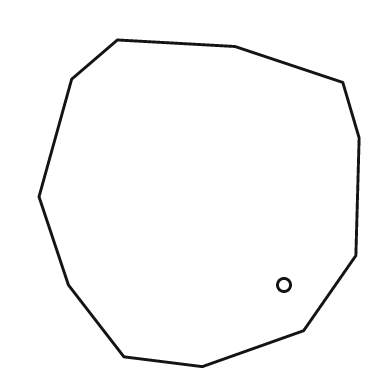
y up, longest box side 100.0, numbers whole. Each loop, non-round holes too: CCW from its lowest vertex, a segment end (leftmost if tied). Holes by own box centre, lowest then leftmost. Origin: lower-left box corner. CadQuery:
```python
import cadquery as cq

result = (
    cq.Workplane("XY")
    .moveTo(50.0, 0.0)
    .lineTo(81.0, 11.0)
    .lineTo(97.0, 34.0)
    .lineTo(98.0, 70.0)
    .lineTo(93.0, 87.0)
    .lineTo(60.0, 98.0)
    .lineTo(24.0, 100.0)
    .lineTo(10.0, 88.0)
    .lineTo(0.0, 52.0)
    .lineTo(9.0, 25.0)
    .lineTo(26.0, 3.0)
    .close()
    .moveTo(75.0, 25.0)
    .circle(2.0)
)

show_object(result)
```